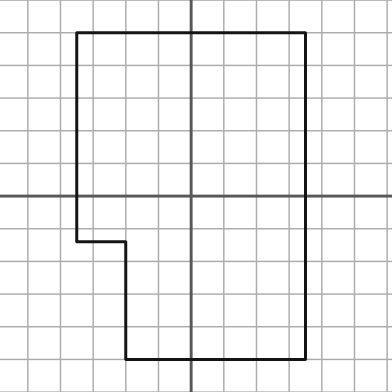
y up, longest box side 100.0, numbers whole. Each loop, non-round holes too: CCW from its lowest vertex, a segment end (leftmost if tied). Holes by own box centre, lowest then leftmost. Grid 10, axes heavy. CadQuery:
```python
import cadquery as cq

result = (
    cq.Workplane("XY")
    .moveTo(-20.0, -50.0)
    .lineTo(35.0, -50.0)
    .lineTo(35.0, 50.0)
    .lineTo(-35.0, 50.0)
    .lineTo(-35.0, -14.0)
    .lineTo(-20.0, -14.0)
    .close()
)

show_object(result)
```